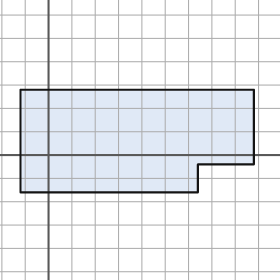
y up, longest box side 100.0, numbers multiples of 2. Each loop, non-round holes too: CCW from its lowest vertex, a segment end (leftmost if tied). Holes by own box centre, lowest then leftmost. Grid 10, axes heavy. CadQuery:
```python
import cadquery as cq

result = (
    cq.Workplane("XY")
    .moveTo(-12.0, -16.0)
    .lineTo(64.0, -16.0)
    .lineTo(64.0, -4.0)
    .lineTo(88.0, -4.0)
    .lineTo(88.0, 28.0)
    .lineTo(-12.0, 28.0)
    .close()
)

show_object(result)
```